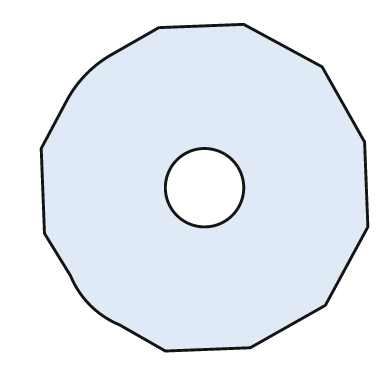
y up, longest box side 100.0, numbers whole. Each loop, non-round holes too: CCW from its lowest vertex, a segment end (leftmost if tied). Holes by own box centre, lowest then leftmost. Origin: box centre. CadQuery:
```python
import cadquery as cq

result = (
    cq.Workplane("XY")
    .moveTo(-12.0, -50.0)
    .lineTo(14.0, -49.0)
    .lineTo(37.0, -36.0)
    .lineTo(50.0, -12.0)
    .lineTo(49.0, 14.0)
    .lineTo(36.0, 37.0)
    .lineTo(12.0, 50.0)
    .lineTo(-14.0, 49.0)
    .lineTo(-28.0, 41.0)
    .threePointArc((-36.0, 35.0), (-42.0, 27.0))
    .lineTo(-50.0, 12.0)
    .lineTo(-49.0, -14.0)
    .lineTo(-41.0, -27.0)
    .threePointArc((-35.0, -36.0), (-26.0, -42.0))
    .close()
    .moveTo(0.0, 0.0)
    .circle(12.0)
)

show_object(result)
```